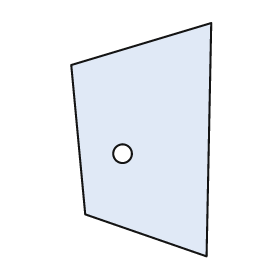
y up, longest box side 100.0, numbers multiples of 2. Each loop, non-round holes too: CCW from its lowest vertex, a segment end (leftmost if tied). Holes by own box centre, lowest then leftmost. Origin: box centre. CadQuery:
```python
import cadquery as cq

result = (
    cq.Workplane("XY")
    .moveTo(28.0, -50.0)
    .lineTo(30.0, 50.0)
    .lineTo(-30.0, 32.0)
    .lineTo(-24.0, -32.0)
    .close()
    .moveTo(-8.0, -6.0)
    .circle(4.0)
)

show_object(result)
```